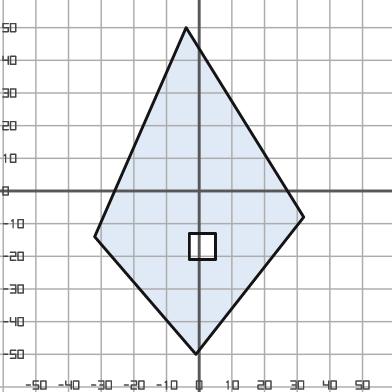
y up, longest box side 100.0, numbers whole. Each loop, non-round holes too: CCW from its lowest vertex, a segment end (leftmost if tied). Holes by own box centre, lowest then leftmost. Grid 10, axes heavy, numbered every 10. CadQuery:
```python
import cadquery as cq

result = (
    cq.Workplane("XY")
    .moveTo(-1.0, -50.0)
    .lineTo(32.0, -8.0)
    .lineTo(-4.0, 50.0)
    .lineTo(-32.0, -14.0)
    .close()
    .moveTo(-3.0, -21.0)
    .lineTo(5.0, -21.0)
    .lineTo(5.0, -13.0)
    .lineTo(-3.0, -13.0)
    .close()
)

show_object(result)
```